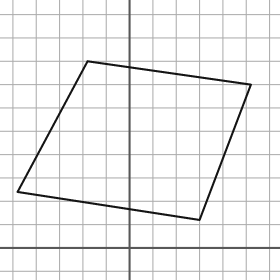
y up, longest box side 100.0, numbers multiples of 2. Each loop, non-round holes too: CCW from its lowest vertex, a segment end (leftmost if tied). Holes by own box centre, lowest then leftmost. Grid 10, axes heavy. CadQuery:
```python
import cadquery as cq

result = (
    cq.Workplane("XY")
    .moveTo(30.0, 12.0)
    .lineTo(52.0, 70.0)
    .lineTo(-18.0, 80.0)
    .lineTo(-48.0, 24.0)
    .close()
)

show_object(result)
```